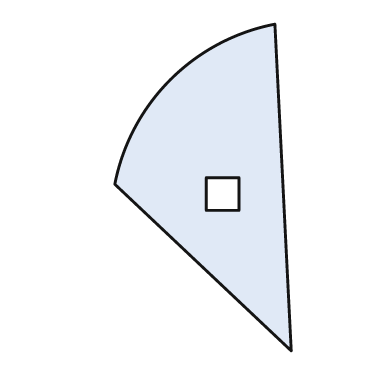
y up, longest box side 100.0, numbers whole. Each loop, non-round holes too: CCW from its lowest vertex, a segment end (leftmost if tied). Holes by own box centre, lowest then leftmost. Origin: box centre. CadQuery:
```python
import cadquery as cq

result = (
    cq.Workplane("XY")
    .moveTo(27.0, -50.0)
    .lineTo(22.0, 50.0)
    .threePointArc((-10.0, 33.0), (-27.0, 1.0))
    .close()
    .moveTo(1.0, -7.0)
    .lineTo(11.0, -7.0)
    .lineTo(11.0, 3.0)
    .lineTo(1.0, 3.0)
    .close()
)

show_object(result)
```